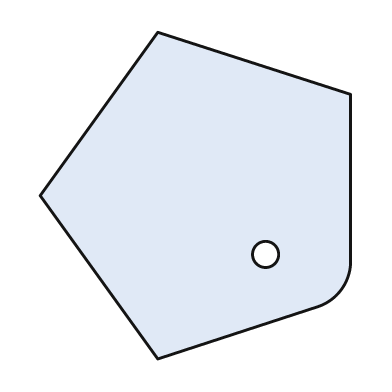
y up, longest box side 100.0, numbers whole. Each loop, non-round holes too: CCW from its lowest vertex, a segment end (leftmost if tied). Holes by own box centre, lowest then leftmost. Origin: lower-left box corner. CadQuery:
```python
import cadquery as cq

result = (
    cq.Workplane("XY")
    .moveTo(36.0, 0.0)
    .lineTo(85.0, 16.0)
    .threePointArc((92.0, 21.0), (95.0, 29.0))
    .lineTo(95.0, 81.0)
    .lineTo(36.0, 100.0)
    .lineTo(0.0, 50.0)
    .close()
    .moveTo(69.0, 32.0)
    .circle(4.0)
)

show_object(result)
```